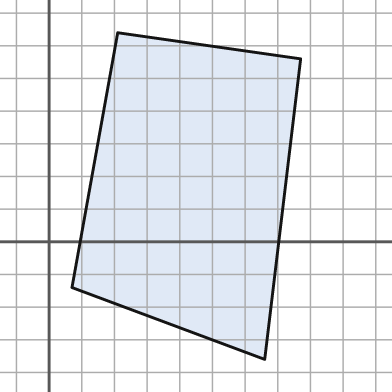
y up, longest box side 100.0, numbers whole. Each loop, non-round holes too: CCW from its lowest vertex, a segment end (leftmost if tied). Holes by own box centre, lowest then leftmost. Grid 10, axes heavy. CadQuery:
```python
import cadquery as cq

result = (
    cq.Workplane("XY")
    .moveTo(66.0, -36.0)
    .lineTo(77.0, 56.0)
    .lineTo(21.0, 64.0)
    .lineTo(7.0, -14.0)
    .close()
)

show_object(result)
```